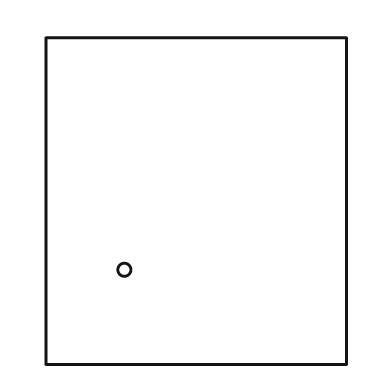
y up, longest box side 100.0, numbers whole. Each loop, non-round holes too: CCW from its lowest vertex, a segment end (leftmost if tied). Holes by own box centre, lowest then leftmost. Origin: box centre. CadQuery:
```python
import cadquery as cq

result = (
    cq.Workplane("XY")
    .moveTo(-46.0, -50.0)
    .lineTo(46.0, -50.0)
    .lineTo(46.0, 50.0)
    .lineTo(-46.0, 50.0)
    .close()
    .moveTo(-22.0, -21.0)
    .circle(2.0)
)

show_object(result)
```